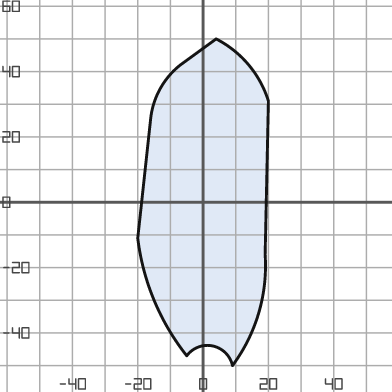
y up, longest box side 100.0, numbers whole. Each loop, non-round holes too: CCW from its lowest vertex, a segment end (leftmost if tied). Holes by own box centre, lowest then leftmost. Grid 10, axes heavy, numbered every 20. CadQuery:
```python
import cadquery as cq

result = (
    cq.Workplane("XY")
    .moveTo(9.0, -50.0)
    .threePointArc((17.0, -34.0), (19.0, -16.0))
    .lineTo(20.0, 31.0)
    .threePointArc((14.0, 42.0), (4.0, 50.0))
    .lineTo(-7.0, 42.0)
    .threePointArc((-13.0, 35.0), (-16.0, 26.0))
    .lineTo(-20.0, -11.0)
    .threePointArc((-15.0, -30.0), (-5.0, -47.0))
    .threePointArc((3.0, -44.0), (9.0, -50.0))
    .close()
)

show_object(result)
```